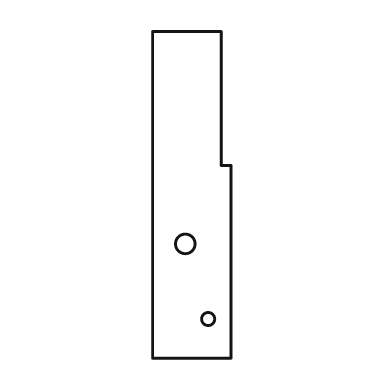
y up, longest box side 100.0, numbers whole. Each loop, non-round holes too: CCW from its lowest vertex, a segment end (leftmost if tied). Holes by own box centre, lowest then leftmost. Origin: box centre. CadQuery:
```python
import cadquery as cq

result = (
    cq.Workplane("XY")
    .moveTo(-12.0, -50.0)
    .lineTo(12.0, -50.0)
    .lineTo(12.0, 9.0)
    .lineTo(9.0, 9.0)
    .lineTo(9.0, 50.0)
    .lineTo(-12.0, 50.0)
    .close()
    .moveTo(5.0, -38.0)
    .circle(2.0)
    .moveTo(-2.0, -15.0)
    .circle(3.0)
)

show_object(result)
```